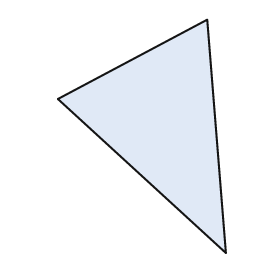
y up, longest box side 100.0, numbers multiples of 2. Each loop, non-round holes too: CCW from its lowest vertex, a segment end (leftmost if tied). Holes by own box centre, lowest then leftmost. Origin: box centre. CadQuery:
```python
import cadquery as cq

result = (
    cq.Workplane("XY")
    .moveTo(36.0, -50.0)
    .lineTo(28.0, 50.0)
    .lineTo(-36.0, 16.0)
    .close()
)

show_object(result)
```